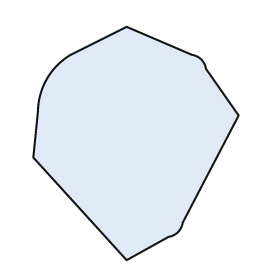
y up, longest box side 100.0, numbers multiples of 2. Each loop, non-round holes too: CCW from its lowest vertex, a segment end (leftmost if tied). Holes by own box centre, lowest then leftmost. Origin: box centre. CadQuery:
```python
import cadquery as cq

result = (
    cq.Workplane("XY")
    .moveTo(-4.0, -50.0)
    .lineTo(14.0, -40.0)
    .threePointArc((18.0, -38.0), (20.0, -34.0))
    .lineTo(44.0, 12.0)
    .lineTo(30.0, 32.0)
    .threePointArc((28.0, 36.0), (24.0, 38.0))
    .lineTo(-4.0, 50.0)
    .lineTo(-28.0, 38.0)
    .threePointArc((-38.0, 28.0), (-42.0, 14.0))
    .lineTo(-44.0, -6.0)
    .close()
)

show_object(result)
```